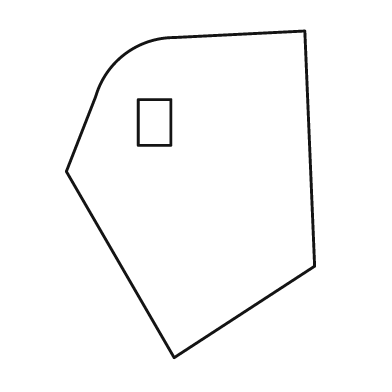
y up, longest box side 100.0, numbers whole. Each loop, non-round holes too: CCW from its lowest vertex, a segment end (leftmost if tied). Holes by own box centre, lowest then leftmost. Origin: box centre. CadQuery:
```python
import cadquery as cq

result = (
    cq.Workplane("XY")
    .moveTo(-5.0, -50.0)
    .lineTo(38.0, -22.0)
    .lineTo(35.0, 50.0)
    .lineTo(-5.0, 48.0)
    .threePointArc((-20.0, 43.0), (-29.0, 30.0))
    .lineTo(-38.0, 7.0)
    .close()
    .moveTo(-16.0, 15.0)
    .lineTo(-6.0, 15.0)
    .lineTo(-6.0, 29.0)
    .lineTo(-16.0, 29.0)
    .close()
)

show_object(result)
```